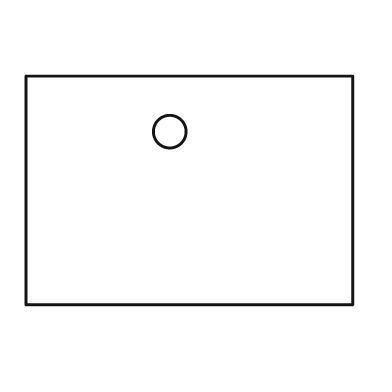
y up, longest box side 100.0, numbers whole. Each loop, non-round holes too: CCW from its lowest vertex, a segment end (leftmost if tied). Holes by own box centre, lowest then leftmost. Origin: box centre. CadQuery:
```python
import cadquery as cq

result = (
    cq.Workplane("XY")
    .moveTo(-50.0, -35.0)
    .lineTo(50.0, -35.0)
    .lineTo(50.0, 35.0)
    .lineTo(-50.0, 35.0)
    .close()
    .moveTo(-6.0, 18.0)
    .circle(5.0)
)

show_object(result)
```